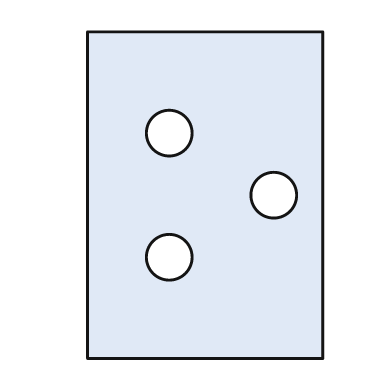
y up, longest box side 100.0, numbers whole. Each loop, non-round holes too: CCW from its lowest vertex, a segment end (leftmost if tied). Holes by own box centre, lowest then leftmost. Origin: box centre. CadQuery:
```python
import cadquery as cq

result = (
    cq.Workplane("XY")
    .moveTo(-36.0, -50.0)
    .lineTo(36.0, -50.0)
    .lineTo(36.0, 50.0)
    .lineTo(-36.0, 50.0)
    .close()
    .moveTo(-11.0, -19.0)
    .circle(7.0)
    .moveTo(21.0, 0.0)
    .circle(7.0)
    .moveTo(-11.0, 19.0)
    .circle(7.0)
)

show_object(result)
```